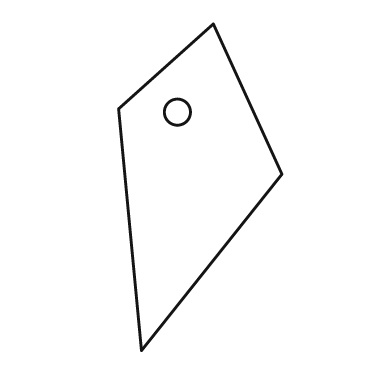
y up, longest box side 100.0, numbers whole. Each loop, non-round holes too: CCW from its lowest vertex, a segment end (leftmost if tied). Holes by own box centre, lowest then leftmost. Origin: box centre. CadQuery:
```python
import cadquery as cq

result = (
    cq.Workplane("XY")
    .moveTo(-18.0, -50.0)
    .lineTo(25.0, 4.0)
    .lineTo(4.0, 50.0)
    .lineTo(-25.0, 24.0)
    .close()
    .moveTo(-7.0, 23.0)
    .circle(4.0)
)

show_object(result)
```